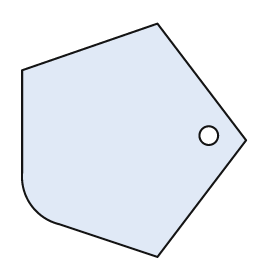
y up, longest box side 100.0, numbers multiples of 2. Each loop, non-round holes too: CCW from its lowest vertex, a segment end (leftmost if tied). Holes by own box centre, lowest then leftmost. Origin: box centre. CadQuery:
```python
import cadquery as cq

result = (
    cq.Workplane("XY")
    .moveTo(10.0, -50.0)
    .lineTo(48.0, 0.0)
    .lineTo(10.0, 50.0)
    .lineTo(-48.0, 30.0)
    .lineTo(-48.0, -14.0)
    .threePointArc((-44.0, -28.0), (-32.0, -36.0))
    .close()
    .moveTo(32.0, 2.0)
    .circle(4.0)
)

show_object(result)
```